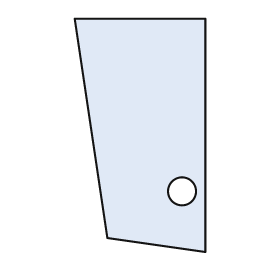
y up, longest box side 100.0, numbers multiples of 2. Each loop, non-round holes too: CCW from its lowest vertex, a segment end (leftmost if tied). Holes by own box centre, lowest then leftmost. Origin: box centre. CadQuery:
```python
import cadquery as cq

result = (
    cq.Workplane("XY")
    .moveTo(28.0, -50.0)
    .lineTo(28.0, 50.0)
    .lineTo(-28.0, 50.0)
    .lineTo(-14.0, -44.0)
    .close()
    .moveTo(18.0, -24.0)
    .circle(6.0)
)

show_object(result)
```